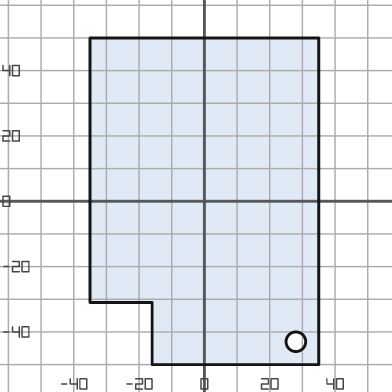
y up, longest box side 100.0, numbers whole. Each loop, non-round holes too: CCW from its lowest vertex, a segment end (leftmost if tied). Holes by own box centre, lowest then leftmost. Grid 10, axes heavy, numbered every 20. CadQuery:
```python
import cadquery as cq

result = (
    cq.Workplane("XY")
    .moveTo(-16.0, -50.0)
    .lineTo(35.0, -50.0)
    .lineTo(35.0, 50.0)
    .lineTo(-35.0, 50.0)
    .lineTo(-35.0, -31.0)
    .lineTo(-16.0, -31.0)
    .close()
    .moveTo(28.0, -43.0)
    .circle(3.0)
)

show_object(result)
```